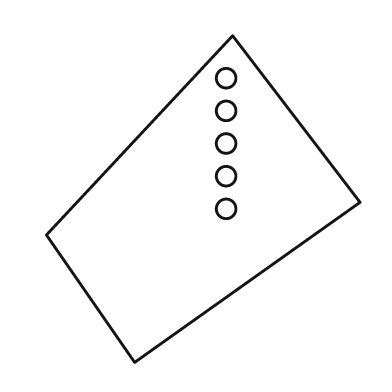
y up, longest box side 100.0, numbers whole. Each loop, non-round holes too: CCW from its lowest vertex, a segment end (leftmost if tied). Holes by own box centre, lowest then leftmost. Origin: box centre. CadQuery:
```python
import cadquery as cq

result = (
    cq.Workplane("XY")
    .moveTo(-21.0, -50.0)
    .lineTo(48.0, -1.0)
    .lineTo(9.0, 50.0)
    .lineTo(-48.0, -11.0)
    .close()
    .moveTo(7.0, -3.0)
    .circle(3.0)
    .moveTo(7.0, 7.0)
    .circle(3.0)
    .moveTo(7.0, 17.0)
    .circle(3.0)
    .moveTo(7.0, 27.0)
    .circle(3.0)
    .moveTo(7.0, 37.0)
    .circle(3.0)
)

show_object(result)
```